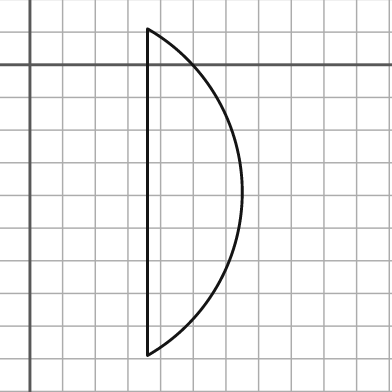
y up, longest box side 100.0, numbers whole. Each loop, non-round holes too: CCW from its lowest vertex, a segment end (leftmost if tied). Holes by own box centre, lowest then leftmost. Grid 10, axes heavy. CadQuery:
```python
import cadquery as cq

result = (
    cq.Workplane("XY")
    .moveTo(36.0, -89.0)
    .threePointArc((65.0, -39.0), (36.0, 11.0))
    .close()
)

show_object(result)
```